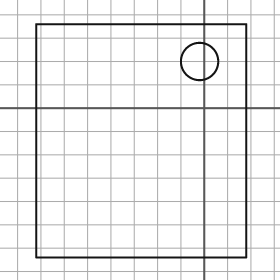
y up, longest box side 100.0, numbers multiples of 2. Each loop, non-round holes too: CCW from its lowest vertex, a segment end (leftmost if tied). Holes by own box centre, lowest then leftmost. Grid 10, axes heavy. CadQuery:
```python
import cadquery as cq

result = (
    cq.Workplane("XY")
    .moveTo(-72.0, -64.0)
    .lineTo(18.0, -64.0)
    .lineTo(18.0, 36.0)
    .lineTo(-72.0, 36.0)
    .close()
    .moveTo(-2.0, 20.0)
    .circle(8.0)
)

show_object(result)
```